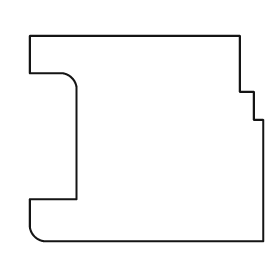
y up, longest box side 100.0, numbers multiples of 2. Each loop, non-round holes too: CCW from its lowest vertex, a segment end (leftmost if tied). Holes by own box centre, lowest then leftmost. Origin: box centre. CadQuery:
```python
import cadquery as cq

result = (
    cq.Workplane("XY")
    .moveTo(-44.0, -44.0)
    .lineTo(50.0, -44.0)
    .lineTo(50.0, 8.0)
    .lineTo(46.0, 8.0)
    .lineTo(46.0, 20.0)
    .lineTo(40.0, 20.0)
    .lineTo(40.0, 44.0)
    .lineTo(-50.0, 44.0)
    .lineTo(-50.0, 28.0)
    .lineTo(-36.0, 28.0)
    .threePointArc((-32.0, 26.0), (-30.0, 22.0))
    .lineTo(-30.0, -26.0)
    .lineTo(-50.0, -26.0)
    .lineTo(-50.0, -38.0)
    .threePointArc((-48.0, -42.0), (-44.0, -44.0))
    .close()
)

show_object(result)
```